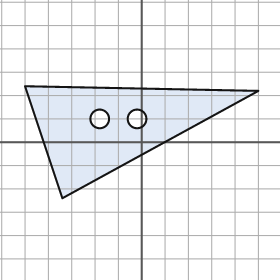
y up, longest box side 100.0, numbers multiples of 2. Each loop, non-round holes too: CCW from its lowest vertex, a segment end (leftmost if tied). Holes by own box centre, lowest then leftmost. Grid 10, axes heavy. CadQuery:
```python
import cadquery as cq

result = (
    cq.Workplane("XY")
    .moveTo(-34.0, -24.0)
    .lineTo(50.0, 22.0)
    .lineTo(-50.0, 24.0)
    .close()
    .moveTo(-18.0, 10.0)
    .circle(4.0)
    .moveTo(-2.0, 10.0)
    .circle(4.0)
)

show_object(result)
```